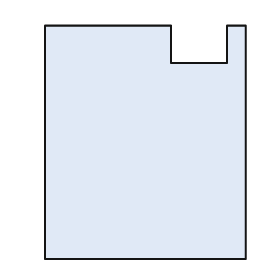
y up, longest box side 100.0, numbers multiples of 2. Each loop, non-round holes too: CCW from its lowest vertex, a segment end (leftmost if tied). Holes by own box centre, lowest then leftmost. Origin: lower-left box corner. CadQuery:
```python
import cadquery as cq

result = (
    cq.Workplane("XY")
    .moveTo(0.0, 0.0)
    .lineTo(86.0, 0.0)
    .lineTo(86.0, 100.0)
    .lineTo(78.0, 100.0)
    .lineTo(78.0, 84.0)
    .lineTo(54.0, 84.0)
    .lineTo(54.0, 100.0)
    .lineTo(0.0, 100.0)
    .close()
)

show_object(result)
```